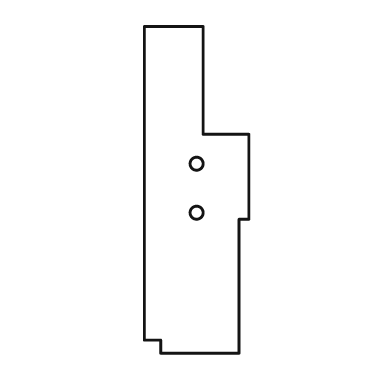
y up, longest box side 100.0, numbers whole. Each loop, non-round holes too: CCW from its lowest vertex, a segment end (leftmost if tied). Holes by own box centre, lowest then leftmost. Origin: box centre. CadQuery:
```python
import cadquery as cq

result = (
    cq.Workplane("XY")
    .moveTo(-11.0, -50.0)
    .lineTo(13.0, -50.0)
    .lineTo(13.0, -9.0)
    .lineTo(16.0, -9.0)
    .lineTo(16.0, 17.0)
    .lineTo(2.0, 17.0)
    .lineTo(2.0, 50.0)
    .lineTo(-16.0, 50.0)
    .lineTo(-16.0, -46.0)
    .lineTo(-11.0, -46.0)
    .close()
    .moveTo(0.0, -7.0)
    .circle(2.0)
    .moveTo(0.0, 8.0)
    .circle(2.0)
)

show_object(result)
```